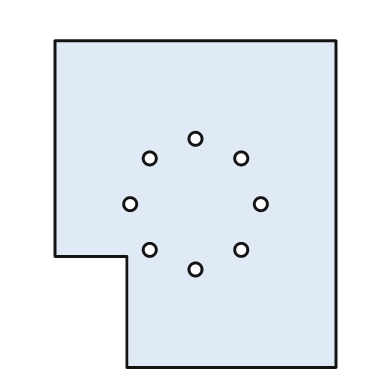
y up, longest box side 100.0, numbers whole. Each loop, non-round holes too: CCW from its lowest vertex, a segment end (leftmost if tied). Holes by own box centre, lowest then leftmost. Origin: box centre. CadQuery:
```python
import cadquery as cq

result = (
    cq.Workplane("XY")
    .moveTo(-21.0, -50.0)
    .lineTo(43.0, -50.0)
    .lineTo(43.0, 50.0)
    .lineTo(-43.0, 50.0)
    .lineTo(-43.0, -16.0)
    .lineTo(-21.0, -16.0)
    .close()
    .moveTo(0.0, -20.0)
    .circle(2.0)
    .moveTo(-14.0, -14.0)
    .circle(2.0)
    .moveTo(14.0, -14.0)
    .circle(2.0)
    .moveTo(-20.0, 0.0)
    .circle(2.0)
    .moveTo(20.0, 0.0)
    .circle(2.0)
    .moveTo(-14.0, 14.0)
    .circle(2.0)
    .moveTo(14.0, 14.0)
    .circle(2.0)
    .moveTo(0.0, 20.0)
    .circle(2.0)
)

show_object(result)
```